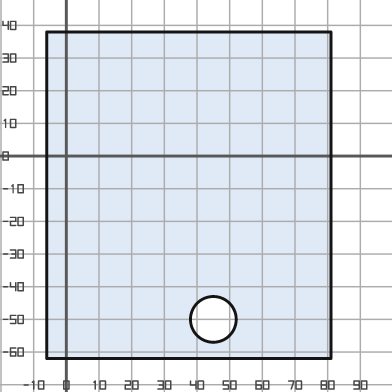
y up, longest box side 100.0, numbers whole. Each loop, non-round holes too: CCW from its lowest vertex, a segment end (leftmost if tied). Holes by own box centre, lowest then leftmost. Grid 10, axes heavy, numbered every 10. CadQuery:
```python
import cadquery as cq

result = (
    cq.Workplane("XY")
    .moveTo(-6.0, -62.0)
    .lineTo(81.0, -62.0)
    .lineTo(81.0, 38.0)
    .lineTo(-6.0, 38.0)
    .close()
    .moveTo(45.0, -50.0)
    .circle(7.0)
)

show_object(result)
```